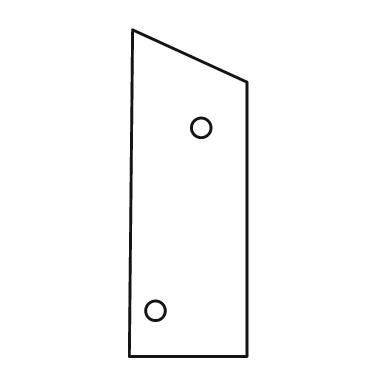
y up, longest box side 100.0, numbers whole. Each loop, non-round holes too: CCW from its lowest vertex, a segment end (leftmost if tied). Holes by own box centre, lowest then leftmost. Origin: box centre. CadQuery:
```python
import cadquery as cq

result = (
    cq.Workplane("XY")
    .moveTo(-18.0, -50.0)
    .lineTo(18.0, -50.0)
    .lineTo(18.0, 34.0)
    .lineTo(-17.0, 50.0)
    .close()
    .moveTo(-10.0, -36.0)
    .circle(3.0)
    .moveTo(4.0, 20.0)
    .circle(3.0)
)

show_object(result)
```